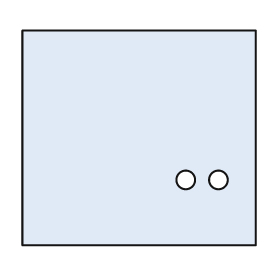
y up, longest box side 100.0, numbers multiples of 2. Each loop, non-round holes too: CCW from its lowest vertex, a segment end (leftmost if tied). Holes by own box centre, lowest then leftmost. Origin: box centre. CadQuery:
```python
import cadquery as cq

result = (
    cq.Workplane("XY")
    .moveTo(-50.0, -46.0)
    .lineTo(50.0, -46.0)
    .lineTo(50.0, 46.0)
    .lineTo(-50.0, 46.0)
    .close()
    .moveTo(20.0, -18.0)
    .circle(4.0)
    .moveTo(34.0, -18.0)
    .circle(4.0)
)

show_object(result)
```